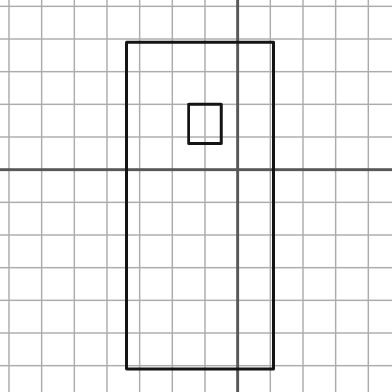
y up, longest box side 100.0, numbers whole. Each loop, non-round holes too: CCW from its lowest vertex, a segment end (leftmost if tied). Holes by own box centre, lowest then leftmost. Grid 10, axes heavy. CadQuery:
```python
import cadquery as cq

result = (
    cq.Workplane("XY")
    .moveTo(-34.0, -61.0)
    .lineTo(11.0, -61.0)
    .lineTo(11.0, 39.0)
    .lineTo(-34.0, 39.0)
    .close()
    .moveTo(-15.0, 8.0)
    .lineTo(-5.0, 8.0)
    .lineTo(-5.0, 20.0)
    .lineTo(-15.0, 20.0)
    .close()
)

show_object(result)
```